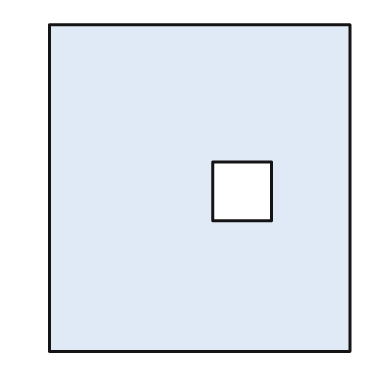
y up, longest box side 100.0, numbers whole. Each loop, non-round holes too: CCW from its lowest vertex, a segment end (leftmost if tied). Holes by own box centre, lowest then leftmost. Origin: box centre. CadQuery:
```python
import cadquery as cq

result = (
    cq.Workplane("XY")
    .moveTo(-46.0, -50.0)
    .lineTo(46.0, -50.0)
    .lineTo(46.0, 50.0)
    .lineTo(-46.0, 50.0)
    .close()
    .moveTo(4.0, -10.0)
    .lineTo(22.0, -10.0)
    .lineTo(22.0, 8.0)
    .lineTo(4.0, 8.0)
    .close()
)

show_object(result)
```